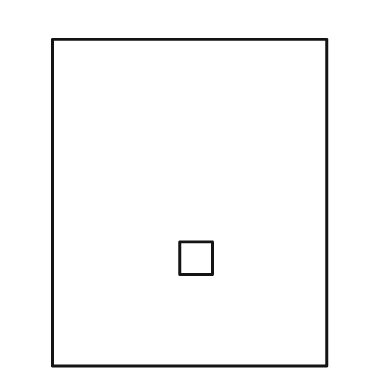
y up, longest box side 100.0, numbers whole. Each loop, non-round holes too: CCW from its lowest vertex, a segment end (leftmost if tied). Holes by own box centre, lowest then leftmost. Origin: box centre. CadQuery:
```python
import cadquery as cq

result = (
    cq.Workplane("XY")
    .moveTo(-42.0, -50.0)
    .lineTo(42.0, -50.0)
    .lineTo(42.0, 50.0)
    .lineTo(-42.0, 50.0)
    .close()
    .moveTo(-3.0, -22.0)
    .lineTo(7.0, -22.0)
    .lineTo(7.0, -12.0)
    .lineTo(-3.0, -12.0)
    .close()
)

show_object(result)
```